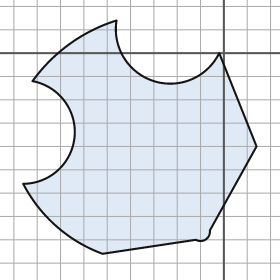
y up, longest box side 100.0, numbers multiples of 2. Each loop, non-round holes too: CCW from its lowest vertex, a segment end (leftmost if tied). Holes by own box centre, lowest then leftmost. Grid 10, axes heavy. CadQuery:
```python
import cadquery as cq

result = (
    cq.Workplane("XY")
    .moveTo(-52.0, -86.0)
    .lineTo(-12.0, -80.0)
    .threePointArc((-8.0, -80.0), (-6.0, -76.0))
    .lineTo(14.0, -40.0)
    .lineTo(-2.0, 0.0)
    .threePointArc((-30.0, -12.0), (-46.0, 14.0))
    .threePointArc((-66.0, 4.0), (-82.0, -12.0))
    .threePointArc((-64.0, -36.0), (-86.0, -56.0))
    .threePointArc((-72.0, -74.0), (-52.0, -86.0))
    .close()
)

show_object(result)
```